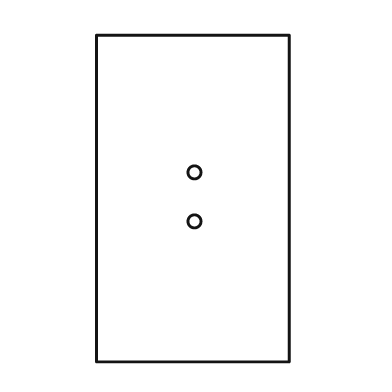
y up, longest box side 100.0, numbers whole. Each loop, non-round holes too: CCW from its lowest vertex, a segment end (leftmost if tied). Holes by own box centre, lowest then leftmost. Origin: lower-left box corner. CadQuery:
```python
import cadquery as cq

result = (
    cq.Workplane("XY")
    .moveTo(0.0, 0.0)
    .lineTo(59.0, 0.0)
    .lineTo(59.0, 100.0)
    .lineTo(0.0, 100.0)
    .close()
    .moveTo(30.0, 43.0)
    .circle(2.0)
    .moveTo(30.0, 58.0)
    .circle(2.0)
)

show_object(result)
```